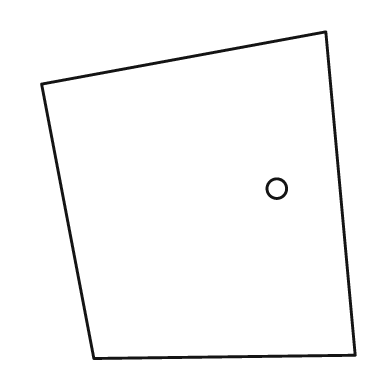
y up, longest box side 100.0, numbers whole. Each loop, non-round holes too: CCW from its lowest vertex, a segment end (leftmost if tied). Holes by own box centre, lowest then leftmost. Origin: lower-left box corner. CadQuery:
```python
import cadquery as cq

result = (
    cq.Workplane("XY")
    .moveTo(16.0, 0.0)
    .lineTo(96.0, 1.0)
    .lineTo(87.0, 100.0)
    .lineTo(0.0, 84.0)
    .close()
    .moveTo(72.0, 52.0)
    .circle(3.0)
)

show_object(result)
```